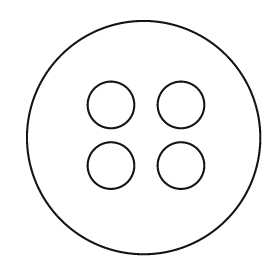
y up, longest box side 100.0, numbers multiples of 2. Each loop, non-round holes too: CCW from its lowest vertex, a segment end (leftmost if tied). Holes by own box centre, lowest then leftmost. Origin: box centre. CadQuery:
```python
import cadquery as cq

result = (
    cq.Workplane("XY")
    .moveTo(0.0, 0.0)
    .circle(50.0)
    .moveTo(-14.0, -12.0)
    .circle(10.0)
    .moveTo(16.0, -12.0)
    .circle(10.0)
    .moveTo(-14.0, 14.0)
    .circle(10.0)
    .moveTo(16.0, 14.0)
    .circle(10.0)
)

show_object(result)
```